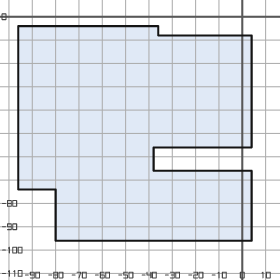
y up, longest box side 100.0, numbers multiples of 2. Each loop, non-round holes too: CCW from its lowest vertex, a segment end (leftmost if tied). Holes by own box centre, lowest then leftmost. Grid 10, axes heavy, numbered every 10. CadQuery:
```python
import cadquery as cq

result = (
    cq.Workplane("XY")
    .moveTo(-80.0, -96.0)
    .lineTo(4.0, -96.0)
    .lineTo(4.0, -66.0)
    .lineTo(-38.0, -66.0)
    .lineTo(-38.0, -56.0)
    .lineTo(4.0, -56.0)
    .lineTo(4.0, -8.0)
    .lineTo(-36.0, -8.0)
    .lineTo(-36.0, -4.0)
    .lineTo(-96.0, -4.0)
    .lineTo(-96.0, -74.0)
    .lineTo(-80.0, -74.0)
    .close()
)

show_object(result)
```